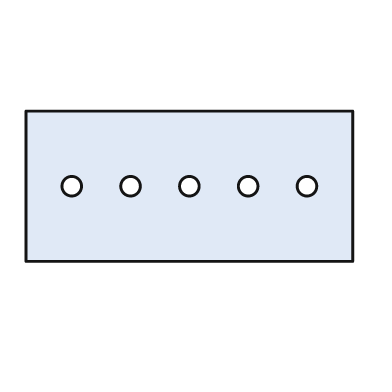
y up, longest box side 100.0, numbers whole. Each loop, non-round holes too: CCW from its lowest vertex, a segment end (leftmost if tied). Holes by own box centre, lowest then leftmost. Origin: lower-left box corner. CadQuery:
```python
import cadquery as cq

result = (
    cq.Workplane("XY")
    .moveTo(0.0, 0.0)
    .lineTo(100.0, 0.0)
    .lineTo(100.0, 46.0)
    .lineTo(0.0, 46.0)
    .close()
    .moveTo(14.0, 23.0)
    .circle(3.0)
    .moveTo(32.0, 23.0)
    .circle(3.0)
    .moveTo(50.0, 23.0)
    .circle(3.0)
    .moveTo(68.0, 23.0)
    .circle(3.0)
    .moveTo(86.0, 23.0)
    .circle(3.0)
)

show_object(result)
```